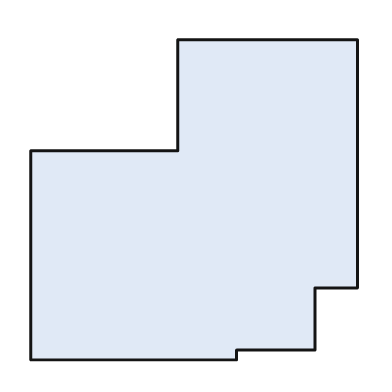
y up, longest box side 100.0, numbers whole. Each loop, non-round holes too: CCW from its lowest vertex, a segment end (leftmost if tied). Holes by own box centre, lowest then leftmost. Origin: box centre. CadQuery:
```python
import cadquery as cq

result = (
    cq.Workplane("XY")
    .moveTo(-50.0, -49.0)
    .lineTo(13.0, -49.0)
    .lineTo(13.0, -46.0)
    .lineTo(37.0, -46.0)
    .lineTo(37.0, -27.0)
    .lineTo(50.0, -27.0)
    .lineTo(50.0, 49.0)
    .lineTo(-5.0, 49.0)
    .lineTo(-5.0, 15.0)
    .lineTo(-50.0, 15.0)
    .close()
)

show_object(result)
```